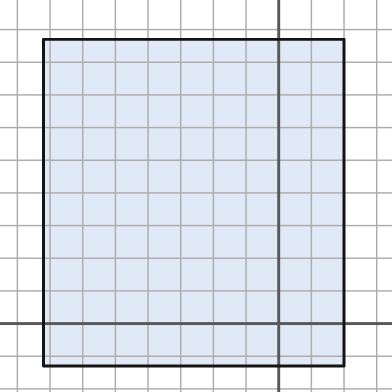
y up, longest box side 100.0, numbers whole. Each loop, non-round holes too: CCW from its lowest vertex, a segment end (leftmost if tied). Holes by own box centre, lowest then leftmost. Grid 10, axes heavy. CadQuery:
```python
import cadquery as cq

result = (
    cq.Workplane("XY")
    .moveTo(-72.0, -13.0)
    .lineTo(20.0, -13.0)
    .lineTo(20.0, 87.0)
    .lineTo(-72.0, 87.0)
    .close()
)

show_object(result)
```